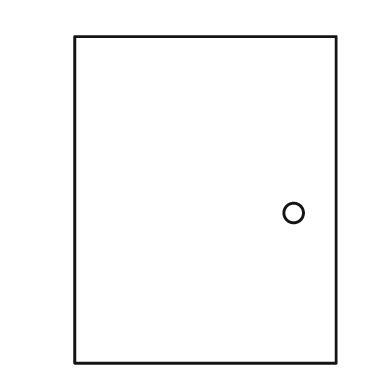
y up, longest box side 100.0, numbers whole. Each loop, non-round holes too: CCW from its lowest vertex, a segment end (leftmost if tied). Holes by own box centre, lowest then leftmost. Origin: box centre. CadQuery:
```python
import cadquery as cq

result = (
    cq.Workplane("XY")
    .moveTo(-40.0, -50.0)
    .lineTo(40.0, -50.0)
    .lineTo(40.0, 50.0)
    .lineTo(-40.0, 50.0)
    .close()
    .moveTo(27.0, -4.0)
    .circle(3.0)
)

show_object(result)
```